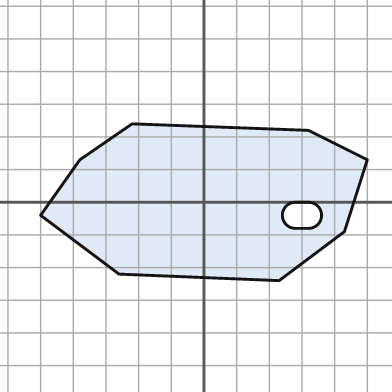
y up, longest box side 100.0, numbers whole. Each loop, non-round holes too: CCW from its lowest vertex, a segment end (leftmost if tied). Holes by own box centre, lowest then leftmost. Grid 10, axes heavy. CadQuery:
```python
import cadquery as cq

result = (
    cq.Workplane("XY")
    .moveTo(23.0, -24.0)
    .lineTo(43.0, -9.0)
    .lineTo(50.0, 13.0)
    .lineTo(32.0, 22.0)
    .lineTo(-22.0, 24.0)
    .lineTo(-38.0, 13.0)
    .lineTo(-50.0, -4.0)
    .lineTo(-26.0, -22.0)
    .close()
    .moveTo(28.0, -8.0)
    .lineTo(32.0, -8.0)
    .threePointArc((36.0, -4.0), (32.0, 0.0))
    .lineTo(28.0, 0.0)
    .threePointArc((24.0, -4.0), (28.0, -8.0))
    .close()
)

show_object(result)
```